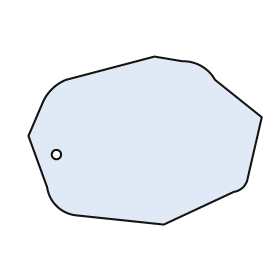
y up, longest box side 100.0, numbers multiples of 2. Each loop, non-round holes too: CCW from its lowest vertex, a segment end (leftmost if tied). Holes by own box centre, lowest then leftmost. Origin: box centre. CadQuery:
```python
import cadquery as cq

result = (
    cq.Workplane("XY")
    .moveTo(8.0, -36.0)
    .lineTo(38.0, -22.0)
    .threePointArc((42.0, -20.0), (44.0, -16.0))
    .lineTo(50.0, 10.0)
    .lineTo(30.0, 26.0)
    .threePointArc((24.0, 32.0), (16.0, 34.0))
    .lineTo(4.0, 36.0)
    .lineTo(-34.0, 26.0)
    .threePointArc((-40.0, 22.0), (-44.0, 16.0))
    .lineTo(-50.0, 2.0)
    .lineTo(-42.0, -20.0)
    .threePointArc((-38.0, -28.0), (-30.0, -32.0))
    .close()
    .moveTo(-38.0, -6.0)
    .circle(2.0)
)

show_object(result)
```